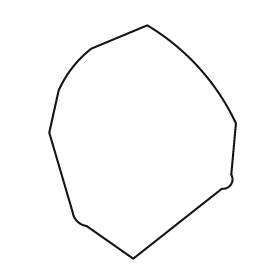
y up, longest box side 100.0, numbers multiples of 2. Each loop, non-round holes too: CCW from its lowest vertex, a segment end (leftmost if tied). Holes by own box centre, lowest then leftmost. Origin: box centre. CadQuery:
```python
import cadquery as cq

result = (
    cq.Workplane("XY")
    .moveTo(-4.0, -50.0)
    .lineTo(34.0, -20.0)
    .threePointArc((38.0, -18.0), (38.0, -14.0))
    .lineTo(40.0, 8.0)
    .threePointArc((24.0, 32.0), (2.0, 50.0))
    .lineTo(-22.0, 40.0)
    .threePointArc((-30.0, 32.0), (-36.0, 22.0))
    .lineTo(-40.0, 4.0)
    .lineTo(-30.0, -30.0)
    .threePointArc((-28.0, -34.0), (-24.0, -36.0))
    .close()
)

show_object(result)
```